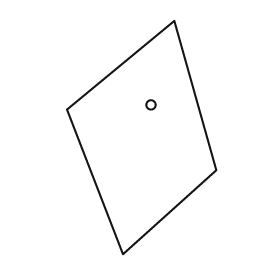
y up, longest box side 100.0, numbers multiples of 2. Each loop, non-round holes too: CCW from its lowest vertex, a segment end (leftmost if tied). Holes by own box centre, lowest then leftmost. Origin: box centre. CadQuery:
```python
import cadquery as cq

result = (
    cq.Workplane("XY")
    .moveTo(-8.0, -50.0)
    .lineTo(32.0, -14.0)
    .lineTo(14.0, 50.0)
    .lineTo(-32.0, 12.0)
    .close()
    .moveTo(4.0, 14.0)
    .circle(2.0)
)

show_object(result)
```